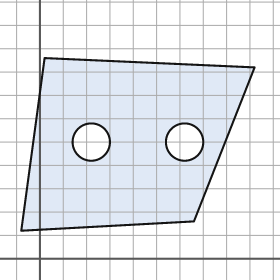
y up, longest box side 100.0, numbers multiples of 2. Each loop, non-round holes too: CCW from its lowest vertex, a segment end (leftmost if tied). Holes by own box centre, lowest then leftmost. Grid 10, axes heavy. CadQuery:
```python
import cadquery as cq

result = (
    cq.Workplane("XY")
    .moveTo(-8.0, 12.0)
    .lineTo(66.0, 16.0)
    .lineTo(92.0, 82.0)
    .lineTo(2.0, 86.0)
    .close()
    .moveTo(22.0, 50.0)
    .circle(8.0)
    .moveTo(62.0, 50.0)
    .circle(8.0)
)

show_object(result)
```